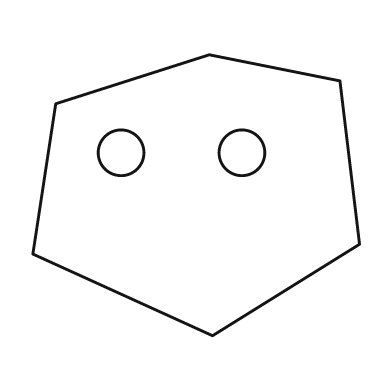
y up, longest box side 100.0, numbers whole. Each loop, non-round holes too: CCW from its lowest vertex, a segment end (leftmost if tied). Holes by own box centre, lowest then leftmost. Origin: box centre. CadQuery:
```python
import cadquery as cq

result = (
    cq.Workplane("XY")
    .moveTo(5.0, -43.0)
    .lineTo(50.0, -15.0)
    .lineTo(44.0, 35.0)
    .lineTo(4.0, 43.0)
    .lineTo(-43.0, 28.0)
    .lineTo(-50.0, -18.0)
    .close()
    .moveTo(-23.0, 13.0)
    .circle(7.0)
    .moveTo(14.0, 13.0)
    .circle(7.0)
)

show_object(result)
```